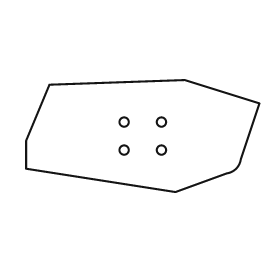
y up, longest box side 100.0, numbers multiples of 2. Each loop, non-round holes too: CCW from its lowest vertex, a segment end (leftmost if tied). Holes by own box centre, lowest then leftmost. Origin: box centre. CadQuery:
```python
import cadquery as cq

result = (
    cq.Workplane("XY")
    .moveTo(14.0, -24.0)
    .lineTo(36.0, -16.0)
    .threePointArc((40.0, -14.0), (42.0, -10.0))
    .lineTo(50.0, 14.0)
    .lineTo(18.0, 24.0)
    .lineTo(-40.0, 22.0)
    .lineTo(-50.0, -2.0)
    .lineTo(-50.0, -14.0)
    .close()
    .moveTo(-8.0, -6.0)
    .circle(2.0)
    .moveTo(8.0, -6.0)
    .circle(2.0)
    .moveTo(-8.0, 6.0)
    .circle(2.0)
    .moveTo(8.0, 6.0)
    .circle(2.0)
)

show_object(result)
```